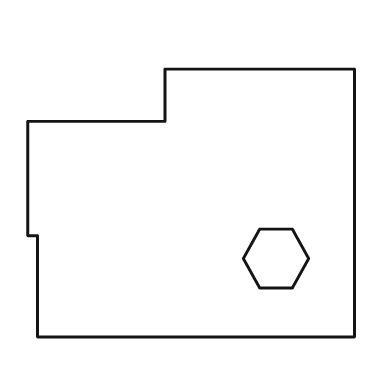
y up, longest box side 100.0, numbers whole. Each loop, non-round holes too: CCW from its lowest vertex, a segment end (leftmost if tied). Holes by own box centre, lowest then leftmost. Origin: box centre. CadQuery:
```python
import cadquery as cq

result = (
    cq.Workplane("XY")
    .moveTo(-47.0, -41.0)
    .lineTo(50.0, -41.0)
    .lineTo(50.0, 41.0)
    .lineTo(-8.0, 41.0)
    .lineTo(-8.0, 25.0)
    .lineTo(-50.0, 25.0)
    .lineTo(-50.0, -10.0)
    .lineTo(-47.0, -10.0)
    .close()
    .moveTo(21.0, -26.0)
    .lineTo(31.0, -26.0)
    .lineTo(36.0, -17.0)
    .lineTo(31.0, -8.0)
    .lineTo(21.0, -8.0)
    .lineTo(16.0, -17.0)
    .close()
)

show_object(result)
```